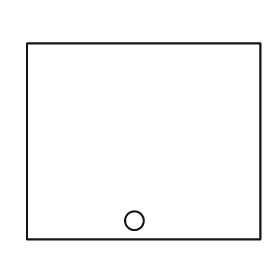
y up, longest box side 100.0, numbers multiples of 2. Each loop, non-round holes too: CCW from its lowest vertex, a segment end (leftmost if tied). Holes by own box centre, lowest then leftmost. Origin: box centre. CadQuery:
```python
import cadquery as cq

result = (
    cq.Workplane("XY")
    .moveTo(-50.0, -42.0)
    .lineTo(50.0, -42.0)
    .lineTo(50.0, 42.0)
    .lineTo(-50.0, 42.0)
    .close()
    .moveTo(-4.0, -34.0)
    .circle(4.0)
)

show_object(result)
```